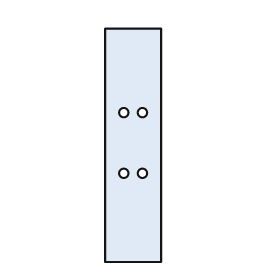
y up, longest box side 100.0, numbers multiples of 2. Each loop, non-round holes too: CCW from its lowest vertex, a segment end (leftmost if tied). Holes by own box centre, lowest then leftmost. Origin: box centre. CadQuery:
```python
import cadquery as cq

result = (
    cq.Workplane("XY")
    .moveTo(-12.0, -50.0)
    .lineTo(12.0, -50.0)
    .lineTo(12.0, 50.0)
    .lineTo(-12.0, 50.0)
    .close()
    .moveTo(-4.0, -12.0)
    .circle(2.0)
    .moveTo(4.0, -12.0)
    .circle(2.0)
    .moveTo(-4.0, 14.0)
    .circle(2.0)
    .moveTo(4.0, 14.0)
    .circle(2.0)
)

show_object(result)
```